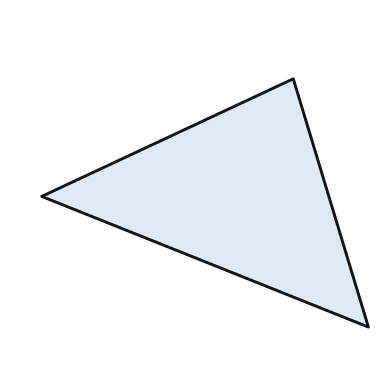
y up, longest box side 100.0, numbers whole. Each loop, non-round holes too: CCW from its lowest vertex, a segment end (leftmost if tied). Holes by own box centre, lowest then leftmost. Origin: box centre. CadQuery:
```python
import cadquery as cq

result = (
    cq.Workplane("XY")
    .moveTo(50.0, -38.0)
    .lineTo(27.0, 38.0)
    .lineTo(-50.0, 2.0)
    .close()
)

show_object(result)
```